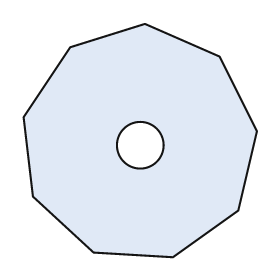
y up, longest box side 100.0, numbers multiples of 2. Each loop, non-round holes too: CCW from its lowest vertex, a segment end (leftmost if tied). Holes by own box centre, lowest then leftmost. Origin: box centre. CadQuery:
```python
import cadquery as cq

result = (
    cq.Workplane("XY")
    .moveTo(14.0, -50.0)
    .lineTo(42.0, -30.0)
    .lineTo(50.0, 4.0)
    .lineTo(34.0, 36.0)
    .lineTo(2.0, 50.0)
    .lineTo(-30.0, 40.0)
    .lineTo(-50.0, 10.0)
    .lineTo(-46.0, -24.0)
    .lineTo(-20.0, -48.0)
    .close()
    .moveTo(0.0, -2.0)
    .circle(10.0)
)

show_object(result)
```